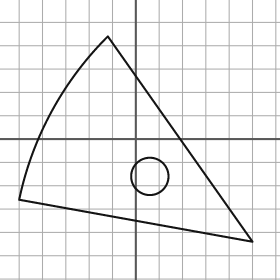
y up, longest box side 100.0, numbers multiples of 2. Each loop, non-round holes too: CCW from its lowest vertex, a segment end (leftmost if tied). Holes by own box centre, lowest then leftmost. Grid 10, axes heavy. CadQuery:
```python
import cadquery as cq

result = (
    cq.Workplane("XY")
    .moveTo(50.0, -44.0)
    .lineTo(-12.0, 44.0)
    .threePointArc((-36.0, 12.0), (-50.0, -26.0))
    .close()
    .moveTo(6.0, -16.0)
    .circle(8.0)
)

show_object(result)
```